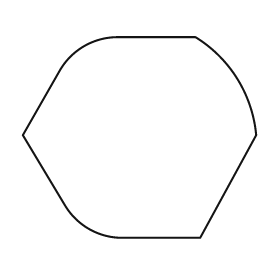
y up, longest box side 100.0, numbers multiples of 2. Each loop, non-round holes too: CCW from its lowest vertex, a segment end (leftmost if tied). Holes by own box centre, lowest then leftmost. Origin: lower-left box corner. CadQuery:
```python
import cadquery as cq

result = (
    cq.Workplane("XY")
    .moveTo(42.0, 0.0)
    .lineTo(76.0, 0.0)
    .lineTo(100.0, 44.0)
    .threePointArc((92.0, 68.0), (74.0, 86.0))
    .lineTo(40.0, 86.0)
    .threePointArc((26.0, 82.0), (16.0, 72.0))
    .lineTo(0.0, 44.0)
    .lineTo(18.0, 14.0)
    .threePointArc((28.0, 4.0), (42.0, 0.0))
    .close()
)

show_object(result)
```